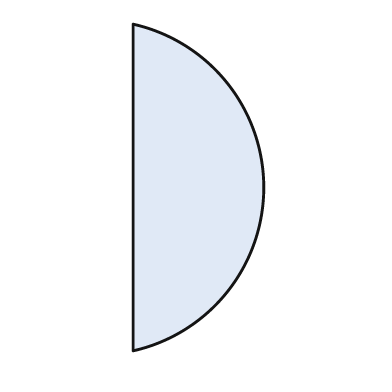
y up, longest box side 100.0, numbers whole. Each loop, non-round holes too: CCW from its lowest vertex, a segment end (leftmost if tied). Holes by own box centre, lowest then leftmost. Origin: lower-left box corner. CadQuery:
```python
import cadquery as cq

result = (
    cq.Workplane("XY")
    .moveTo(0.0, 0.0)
    .threePointArc((40.0, 50.0), (0.0, 100.0))
    .close()
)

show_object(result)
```